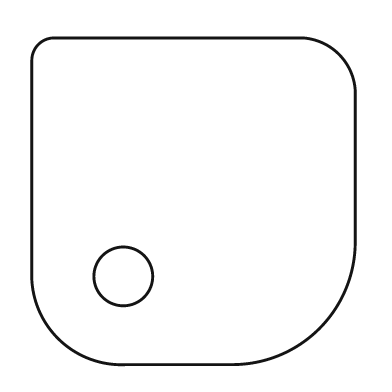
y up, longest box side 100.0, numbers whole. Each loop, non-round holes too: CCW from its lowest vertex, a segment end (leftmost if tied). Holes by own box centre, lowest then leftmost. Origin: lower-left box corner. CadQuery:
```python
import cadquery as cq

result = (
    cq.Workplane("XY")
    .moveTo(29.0, 0.0)
    .lineTo(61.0, 0.0)
    .threePointArc((88.0, 11.0), (99.0, 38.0))
    .lineTo(99.0, 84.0)
    .threePointArc((94.0, 95.0), (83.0, 100.0))
    .lineTo(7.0, 100.0)
    .threePointArc((2.0, 98.0), (0.0, 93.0))
    .lineTo(0.0, 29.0)
    .threePointArc((8.0, 8.0), (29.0, 0.0))
    .close()
    .moveTo(28.0, 27.0)
    .circle(9.0)
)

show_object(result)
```